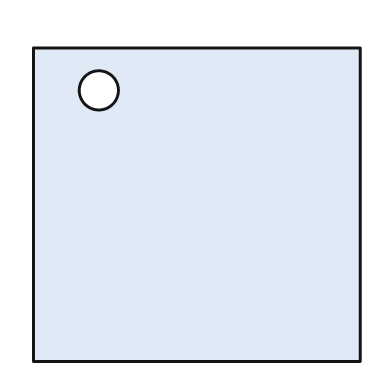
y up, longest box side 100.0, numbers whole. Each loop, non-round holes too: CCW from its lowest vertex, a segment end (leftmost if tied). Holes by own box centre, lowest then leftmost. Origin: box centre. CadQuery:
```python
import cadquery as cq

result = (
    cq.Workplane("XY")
    .moveTo(-50.0, -48.0)
    .lineTo(50.0, -48.0)
    .lineTo(50.0, 48.0)
    .lineTo(-50.0, 48.0)
    .close()
    .moveTo(-30.0, 35.0)
    .circle(6.0)
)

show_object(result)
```